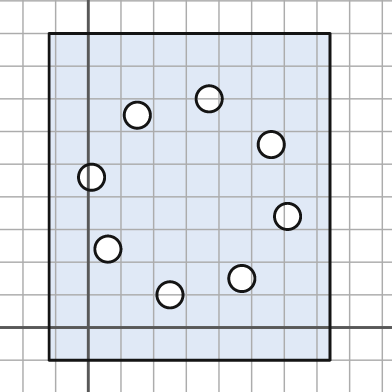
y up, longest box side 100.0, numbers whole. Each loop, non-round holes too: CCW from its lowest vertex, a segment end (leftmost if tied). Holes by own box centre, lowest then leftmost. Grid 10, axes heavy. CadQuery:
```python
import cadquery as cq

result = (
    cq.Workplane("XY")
    .moveTo(-12.0, -10.0)
    .lineTo(74.0, -10.0)
    .lineTo(74.0, 90.0)
    .lineTo(-12.0, 90.0)
    .close()
    .moveTo(25.0, 10.0)
    .circle(4.0)
    .moveTo(47.0, 15.0)
    .circle(4.0)
    .moveTo(6.0, 24.0)
    .circle(4.0)
    .moveTo(61.0, 34.0)
    .circle(4.0)
    .moveTo(1.0, 46.0)
    .circle(4.0)
    .moveTo(56.0, 56.0)
    .circle(4.0)
    .moveTo(15.0, 65.0)
    .circle(4.0)
    .moveTo(37.0, 70.0)
    .circle(4.0)
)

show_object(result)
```